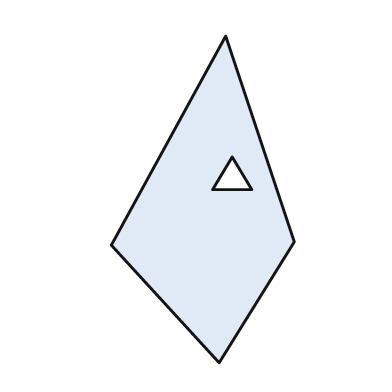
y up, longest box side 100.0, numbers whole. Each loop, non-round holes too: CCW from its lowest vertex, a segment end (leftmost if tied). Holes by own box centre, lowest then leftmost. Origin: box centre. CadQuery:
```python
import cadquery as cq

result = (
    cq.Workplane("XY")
    .moveTo(5.0, -50.0)
    .lineTo(28.0, -13.0)
    .lineTo(7.0, 50.0)
    .lineTo(-28.0, -14.0)
    .close()
    .moveTo(3.0, 3.0)
    .lineTo(15.0, 3.0)
    .lineTo(9.0, 13.0)
    .close()
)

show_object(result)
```